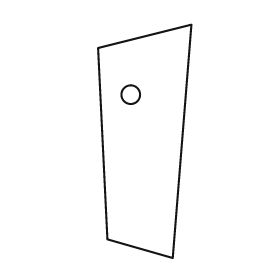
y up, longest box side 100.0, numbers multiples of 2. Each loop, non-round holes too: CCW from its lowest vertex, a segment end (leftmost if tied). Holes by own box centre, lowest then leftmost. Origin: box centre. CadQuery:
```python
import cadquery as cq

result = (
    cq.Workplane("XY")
    .moveTo(12.0, -50.0)
    .lineTo(20.0, 50.0)
    .lineTo(-20.0, 40.0)
    .lineTo(-16.0, -42.0)
    .close()
    .moveTo(-6.0, 20.0)
    .circle(4.0)
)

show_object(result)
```